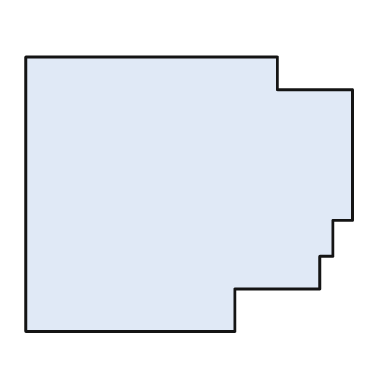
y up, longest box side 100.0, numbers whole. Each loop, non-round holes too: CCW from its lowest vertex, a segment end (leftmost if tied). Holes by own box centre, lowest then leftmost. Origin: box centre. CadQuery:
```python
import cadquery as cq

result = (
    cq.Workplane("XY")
    .moveTo(-50.0, -42.0)
    .lineTo(14.0, -42.0)
    .lineTo(14.0, -29.0)
    .lineTo(40.0, -29.0)
    .lineTo(40.0, -19.0)
    .lineTo(44.0, -19.0)
    .lineTo(44.0, -8.0)
    .lineTo(50.0, -8.0)
    .lineTo(50.0, 32.0)
    .lineTo(27.0, 32.0)
    .lineTo(27.0, 42.0)
    .lineTo(-50.0, 42.0)
    .close()
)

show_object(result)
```